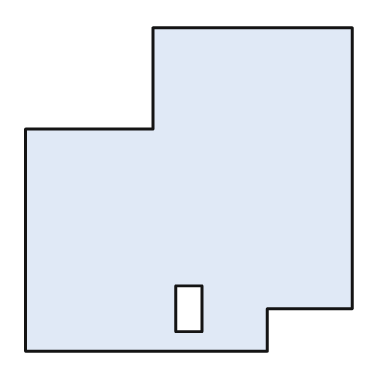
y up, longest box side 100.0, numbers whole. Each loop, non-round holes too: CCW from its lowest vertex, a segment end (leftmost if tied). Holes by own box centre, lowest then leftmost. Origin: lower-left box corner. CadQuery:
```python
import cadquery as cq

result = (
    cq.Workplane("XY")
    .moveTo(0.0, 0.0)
    .lineTo(74.0, 0.0)
    .lineTo(74.0, 13.0)
    .lineTo(100.0, 13.0)
    .lineTo(100.0, 99.0)
    .lineTo(39.0, 99.0)
    .lineTo(39.0, 68.0)
    .lineTo(0.0, 68.0)
    .close()
    .moveTo(46.0, 6.0)
    .lineTo(54.0, 6.0)
    .lineTo(54.0, 20.0)
    .lineTo(46.0, 20.0)
    .close()
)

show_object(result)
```